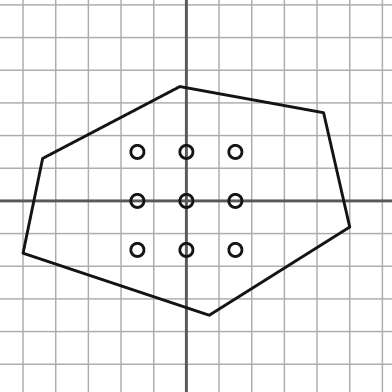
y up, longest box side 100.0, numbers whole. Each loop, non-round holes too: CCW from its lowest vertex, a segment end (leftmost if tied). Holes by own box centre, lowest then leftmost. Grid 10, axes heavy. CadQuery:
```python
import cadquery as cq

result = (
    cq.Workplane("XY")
    .moveTo(7.0, -35.0)
    .lineTo(50.0, -8.0)
    .lineTo(42.0, 27.0)
    .lineTo(-2.0, 35.0)
    .lineTo(-44.0, 13.0)
    .lineTo(-50.0, -16.0)
    .close()
    .moveTo(-15.0, -15.0)
    .circle(2.0)
    .moveTo(0.0, -15.0)
    .circle(2.0)
    .moveTo(15.0, -15.0)
    .circle(2.0)
    .moveTo(-15.0, 0.0)
    .circle(2.0)
    .moveTo(0.0, 0.0)
    .circle(2.0)
    .moveTo(15.0, 0.0)
    .circle(2.0)
    .moveTo(-15.0, 15.0)
    .circle(2.0)
    .moveTo(0.0, 15.0)
    .circle(2.0)
    .moveTo(15.0, 15.0)
    .circle(2.0)
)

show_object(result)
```